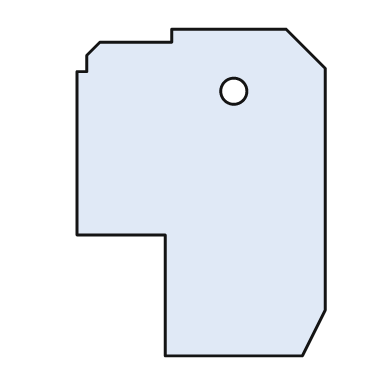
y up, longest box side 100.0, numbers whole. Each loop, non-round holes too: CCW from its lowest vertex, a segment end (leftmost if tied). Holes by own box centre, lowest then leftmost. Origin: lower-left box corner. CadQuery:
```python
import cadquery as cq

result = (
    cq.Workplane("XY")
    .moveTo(27.0, 0.0)
    .lineTo(69.0, 0.0)
    .lineTo(76.0, 14.0)
    .lineTo(76.0, 88.0)
    .lineTo(64.0, 100.0)
    .lineTo(29.0, 100.0)
    .lineTo(29.0, 96.0)
    .lineTo(7.0, 96.0)
    .lineTo(3.0, 92.0)
    .lineTo(3.0, 87.0)
    .lineTo(0.0, 87.0)
    .lineTo(0.0, 37.0)
    .lineTo(27.0, 37.0)
    .close()
    .moveTo(48.0, 81.0)
    .circle(4.0)
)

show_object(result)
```